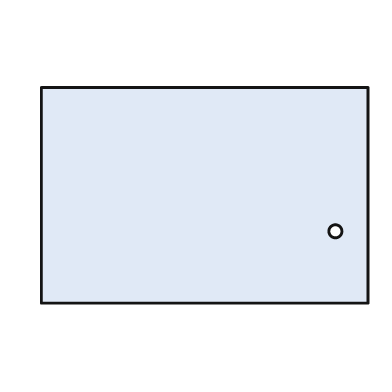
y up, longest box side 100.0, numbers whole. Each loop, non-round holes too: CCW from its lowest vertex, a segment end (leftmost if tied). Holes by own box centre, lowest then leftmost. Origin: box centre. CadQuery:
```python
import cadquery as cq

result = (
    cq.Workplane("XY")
    .moveTo(-50.0, -33.0)
    .lineTo(50.0, -33.0)
    .lineTo(50.0, 33.0)
    .lineTo(-50.0, 33.0)
    .close()
    .moveTo(40.0, -11.0)
    .circle(2.0)
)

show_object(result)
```